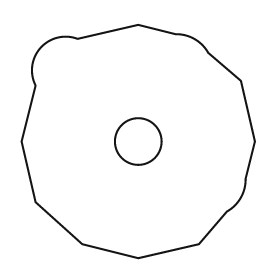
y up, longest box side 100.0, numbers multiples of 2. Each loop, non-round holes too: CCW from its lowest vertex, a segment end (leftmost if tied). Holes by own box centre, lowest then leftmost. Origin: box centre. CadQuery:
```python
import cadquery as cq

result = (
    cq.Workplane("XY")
    .moveTo(0.0, -50.0)
    .lineTo(26.0, -44.0)
    .lineTo(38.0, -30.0)
    .threePointArc((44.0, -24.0), (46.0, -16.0))
    .lineTo(50.0, 0.0)
    .lineTo(44.0, 26.0)
    .lineTo(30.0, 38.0)
    .threePointArc((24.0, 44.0), (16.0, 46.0))
    .lineTo(0.0, 50.0)
    .lineTo(-26.0, 44.0)
    .threePointArc((-42.0, 40.0), (-44.0, 24.0))
    .lineTo(-50.0, 0.0)
    .lineTo(-44.0, -26.0)
    .lineTo(-24.0, -44.0)
    .close()
    .moveTo(0.0, 0.0)
    .circle(10.0)
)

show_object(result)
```